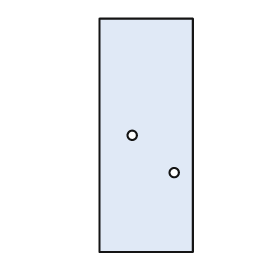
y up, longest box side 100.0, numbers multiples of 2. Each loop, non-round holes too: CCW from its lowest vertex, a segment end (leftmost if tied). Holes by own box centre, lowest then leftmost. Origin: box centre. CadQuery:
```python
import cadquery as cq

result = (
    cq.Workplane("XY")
    .moveTo(-20.0, -50.0)
    .lineTo(20.0, -50.0)
    .lineTo(20.0, 50.0)
    .lineTo(-20.0, 50.0)
    .close()
    .moveTo(12.0, -16.0)
    .circle(2.0)
    .moveTo(-6.0, 0.0)
    .circle(2.0)
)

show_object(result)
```